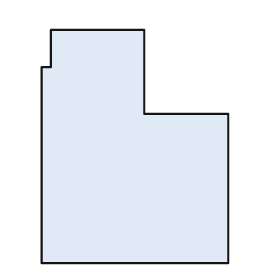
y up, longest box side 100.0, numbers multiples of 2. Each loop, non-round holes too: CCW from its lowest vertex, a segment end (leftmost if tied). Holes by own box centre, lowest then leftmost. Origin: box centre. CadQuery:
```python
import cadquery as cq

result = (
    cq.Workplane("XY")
    .moveTo(-40.0, -50.0)
    .lineTo(40.0, -50.0)
    .lineTo(40.0, 14.0)
    .lineTo(4.0, 14.0)
    .lineTo(4.0, 50.0)
    .lineTo(-36.0, 50.0)
    .lineTo(-36.0, 34.0)
    .lineTo(-40.0, 34.0)
    .close()
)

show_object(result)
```